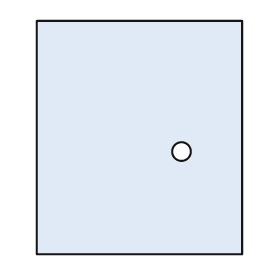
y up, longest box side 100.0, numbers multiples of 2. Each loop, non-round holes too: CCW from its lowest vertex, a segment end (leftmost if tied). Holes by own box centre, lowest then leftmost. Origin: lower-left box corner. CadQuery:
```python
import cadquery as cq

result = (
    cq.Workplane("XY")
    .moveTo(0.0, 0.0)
    .lineTo(88.0, 0.0)
    .lineTo(88.0, 100.0)
    .lineTo(0.0, 100.0)
    .close()
    .moveTo(62.0, 44.0)
    .circle(4.0)
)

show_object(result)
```